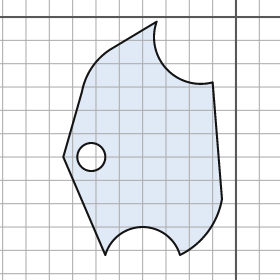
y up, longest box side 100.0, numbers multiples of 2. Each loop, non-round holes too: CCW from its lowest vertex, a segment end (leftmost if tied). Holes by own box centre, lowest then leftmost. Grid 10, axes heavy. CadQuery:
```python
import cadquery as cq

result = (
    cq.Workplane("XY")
    .moveTo(-56.0, -102.0)
    .threePointArc((-40.0, -90.0), (-24.0, -102.0))
    .threePointArc((-12.0, -92.0), (-6.0, -78.0))
    .lineTo(-10.0, -28.0)
    .threePointArc((-30.0, -22.0), (-34.0, -2.0))
    .lineTo(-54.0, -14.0)
    .threePointArc((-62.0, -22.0), (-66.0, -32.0))
    .lineTo(-74.0, -60.0)
    .close()
    .moveTo(-62.0, -60.0)
    .circle(6.0)
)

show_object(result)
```